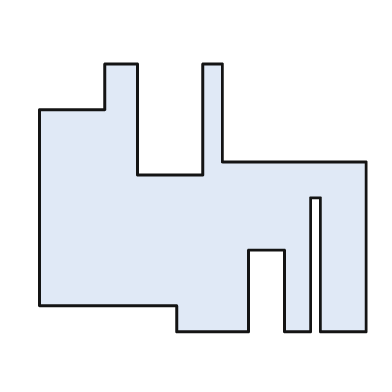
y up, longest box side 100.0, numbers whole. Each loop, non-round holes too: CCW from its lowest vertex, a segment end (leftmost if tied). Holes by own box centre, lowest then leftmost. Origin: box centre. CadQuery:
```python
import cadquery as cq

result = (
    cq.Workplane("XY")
    .moveTo(-8.0, -41.0)
    .lineTo(14.0, -41.0)
    .lineTo(14.0, -16.0)
    .lineTo(25.0, -16.0)
    .lineTo(25.0, -41.0)
    .lineTo(33.0, -41.0)
    .lineTo(33.0, 0.0)
    .lineTo(36.0, 0.0)
    .lineTo(36.0, -41.0)
    .lineTo(50.0, -41.0)
    .lineTo(50.0, 11.0)
    .lineTo(6.0, 11.0)
    .lineTo(6.0, 41.0)
    .lineTo(0.0, 41.0)
    .lineTo(0.0, 7.0)
    .lineTo(-20.0, 7.0)
    .lineTo(-20.0, 41.0)
    .lineTo(-30.0, 41.0)
    .lineTo(-30.0, 27.0)
    .lineTo(-50.0, 27.0)
    .lineTo(-50.0, -33.0)
    .lineTo(-8.0, -33.0)
    .close()
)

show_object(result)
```